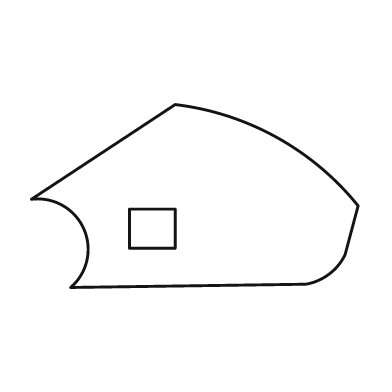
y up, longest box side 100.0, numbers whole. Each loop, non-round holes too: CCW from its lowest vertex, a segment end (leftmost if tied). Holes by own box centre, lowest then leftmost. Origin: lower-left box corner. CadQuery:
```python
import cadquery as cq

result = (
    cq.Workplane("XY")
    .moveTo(12.0, 0.0)
    .lineTo(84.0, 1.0)
    .threePointArc((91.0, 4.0), (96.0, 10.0))
    .lineTo(100.0, 25.0)
    .threePointArc((75.0, 46.0), (44.0, 56.0))
    .lineTo(0.0, 27.0)
    .threePointArc((16.0, 18.0), (12.0, 0.0))
    .close()
    .moveTo(30.0, 12.0)
    .lineTo(44.0, 12.0)
    .lineTo(44.0, 24.0)
    .lineTo(30.0, 24.0)
    .close()
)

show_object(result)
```